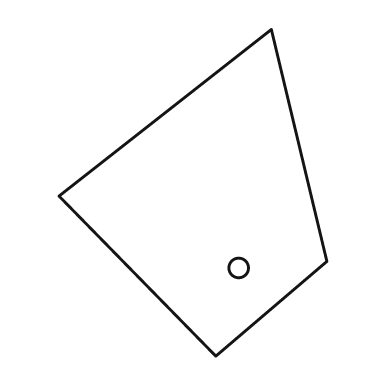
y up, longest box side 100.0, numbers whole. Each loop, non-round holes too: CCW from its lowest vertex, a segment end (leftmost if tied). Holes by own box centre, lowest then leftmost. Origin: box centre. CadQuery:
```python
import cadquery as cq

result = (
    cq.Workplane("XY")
    .moveTo(7.0, -50.0)
    .lineTo(41.0, -21.0)
    .lineTo(24.0, 50.0)
    .lineTo(-41.0, -1.0)
    .close()
    .moveTo(14.0, -23.0)
    .circle(3.0)
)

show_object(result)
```